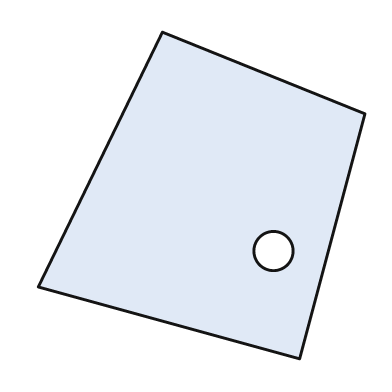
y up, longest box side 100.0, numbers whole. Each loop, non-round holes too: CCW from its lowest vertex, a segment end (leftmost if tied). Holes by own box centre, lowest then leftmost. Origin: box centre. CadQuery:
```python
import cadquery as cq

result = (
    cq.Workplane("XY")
    .moveTo(30.0, -50.0)
    .lineTo(50.0, 25.0)
    .lineTo(-12.0, 50.0)
    .lineTo(-50.0, -28.0)
    .close()
    .moveTo(22.0, -17.0)
    .circle(6.0)
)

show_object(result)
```